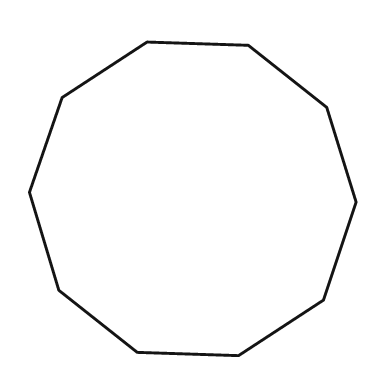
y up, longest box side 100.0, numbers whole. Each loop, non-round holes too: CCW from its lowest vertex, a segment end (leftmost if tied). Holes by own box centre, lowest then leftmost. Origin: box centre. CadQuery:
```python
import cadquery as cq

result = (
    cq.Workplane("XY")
    .moveTo(14.0, -48.0)
    .lineTo(40.0, -31.0)
    .lineTo(50.0, -1.0)
    .lineTo(41.0, 28.0)
    .lineTo(17.0, 47.0)
    .lineTo(-14.0, 48.0)
    .lineTo(-40.0, 31.0)
    .lineTo(-50.0, 2.0)
    .lineTo(-41.0, -28.0)
    .lineTo(-17.0, -47.0)
    .close()
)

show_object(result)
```